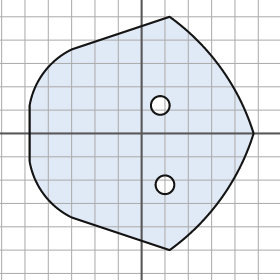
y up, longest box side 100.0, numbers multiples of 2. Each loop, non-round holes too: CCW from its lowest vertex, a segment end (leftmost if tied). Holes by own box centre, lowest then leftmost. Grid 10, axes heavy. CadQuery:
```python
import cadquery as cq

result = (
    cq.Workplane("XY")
    .moveTo(12.0, -50.0)
    .threePointArc((34.0, -28.0), (48.0, 0.0))
    .threePointArc((34.0, 28.0), (12.0, 50.0))
    .lineTo(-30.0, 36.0)
    .threePointArc((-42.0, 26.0), (-48.0, 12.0))
    .lineTo(-48.0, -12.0)
    .threePointArc((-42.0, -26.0), (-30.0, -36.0))
    .close()
    .moveTo(10.0, -22.0)
    .circle(4.0)
    .moveTo(8.0, 12.0)
    .circle(4.0)
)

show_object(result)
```